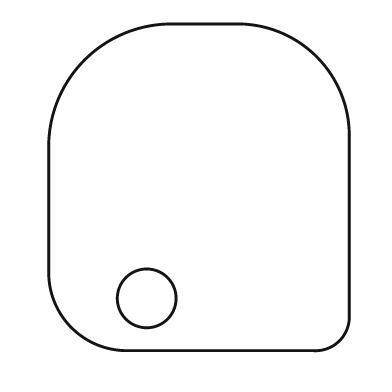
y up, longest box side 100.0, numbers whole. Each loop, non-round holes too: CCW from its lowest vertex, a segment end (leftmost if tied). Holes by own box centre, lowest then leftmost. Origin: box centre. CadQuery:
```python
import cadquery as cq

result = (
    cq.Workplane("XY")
    .moveTo(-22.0, -50.0)
    .lineTo(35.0, -50.0)
    .threePointArc((43.0, -47.0), (46.0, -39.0))
    .lineTo(46.0, 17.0)
    .threePointArc((36.0, 40.0), (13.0, 50.0))
    .lineTo(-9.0, 50.0)
    .threePointArc((-35.0, 39.0), (-46.0, 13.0))
    .lineTo(-46.0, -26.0)
    .threePointArc((-39.0, -43.0), (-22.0, -50.0))
    .close()
    .moveTo(-16.0, -34.0)
    .circle(9.0)
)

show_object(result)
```